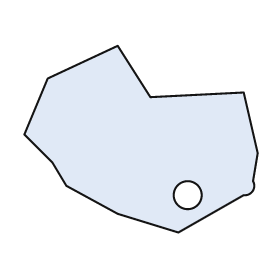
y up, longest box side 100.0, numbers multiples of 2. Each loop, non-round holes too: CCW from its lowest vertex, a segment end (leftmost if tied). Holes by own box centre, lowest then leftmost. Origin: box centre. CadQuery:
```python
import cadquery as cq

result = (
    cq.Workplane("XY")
    .moveTo(16.0, -40.0)
    .lineTo(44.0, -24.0)
    .threePointArc((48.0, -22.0), (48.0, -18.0))
    .lineTo(50.0, -6.0)
    .lineTo(44.0, 20.0)
    .lineTo(4.0, 18.0)
    .lineTo(-10.0, 40.0)
    .lineTo(-40.0, 26.0)
    .lineTo(-50.0, 2.0)
    .lineTo(-38.0, -10.0)
    .lineTo(-32.0, -20.0)
    .lineTo(-10.0, -32.0)
    .close()
    .moveTo(20.0, -24.0)
    .circle(6.0)
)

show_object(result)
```